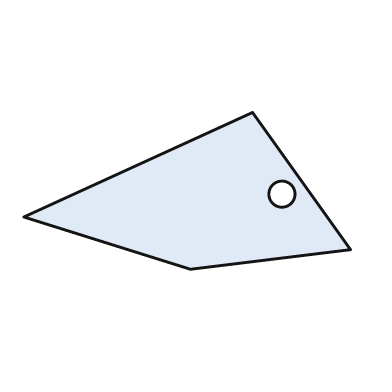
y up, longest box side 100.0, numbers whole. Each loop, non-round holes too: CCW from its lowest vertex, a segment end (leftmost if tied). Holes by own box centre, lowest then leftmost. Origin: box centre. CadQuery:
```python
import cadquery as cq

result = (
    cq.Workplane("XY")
    .moveTo(1.0, -24.0)
    .lineTo(50.0, -18.0)
    .lineTo(20.0, 24.0)
    .lineTo(-50.0, -8.0)
    .close()
    .moveTo(29.0, -1.0)
    .circle(4.0)
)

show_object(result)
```